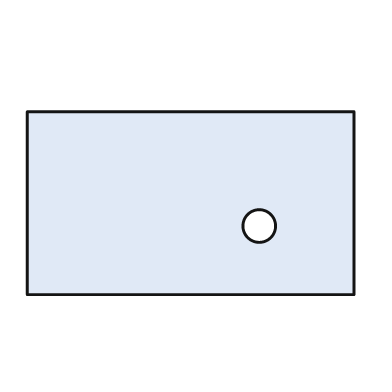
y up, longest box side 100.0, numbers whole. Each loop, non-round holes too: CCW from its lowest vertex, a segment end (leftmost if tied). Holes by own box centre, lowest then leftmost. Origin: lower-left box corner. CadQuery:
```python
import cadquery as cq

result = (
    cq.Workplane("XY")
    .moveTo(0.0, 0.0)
    .lineTo(100.0, 0.0)
    .lineTo(100.0, 56.0)
    .lineTo(0.0, 56.0)
    .close()
    .moveTo(71.0, 21.0)
    .circle(5.0)
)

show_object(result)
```